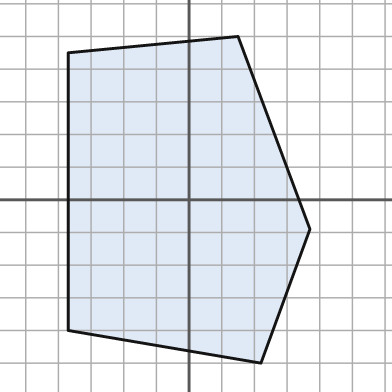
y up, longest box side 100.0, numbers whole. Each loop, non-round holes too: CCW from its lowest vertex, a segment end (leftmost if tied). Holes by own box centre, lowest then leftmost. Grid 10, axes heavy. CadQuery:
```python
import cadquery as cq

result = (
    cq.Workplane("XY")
    .moveTo(22.0, -50.0)
    .lineTo(37.0, -9.0)
    .lineTo(15.0, 50.0)
    .lineTo(-37.0, 45.0)
    .lineTo(-37.0, -40.0)
    .close()
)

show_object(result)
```